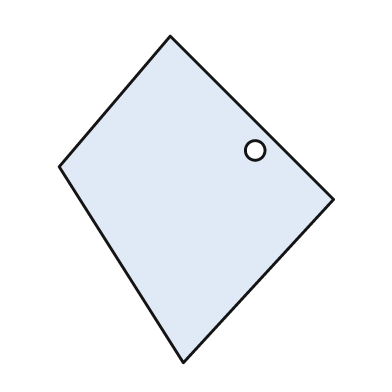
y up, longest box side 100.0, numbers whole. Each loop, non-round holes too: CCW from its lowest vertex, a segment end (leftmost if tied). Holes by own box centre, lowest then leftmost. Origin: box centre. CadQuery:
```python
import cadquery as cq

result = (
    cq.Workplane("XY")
    .moveTo(-4.0, -50.0)
    .lineTo(42.0, 0.0)
    .lineTo(-8.0, 50.0)
    .lineTo(-42.0, 10.0)
    .close()
    .moveTo(18.0, 15.0)
    .circle(3.0)
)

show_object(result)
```